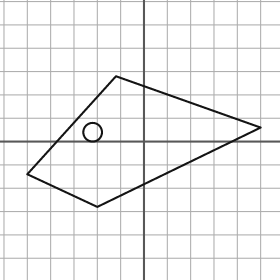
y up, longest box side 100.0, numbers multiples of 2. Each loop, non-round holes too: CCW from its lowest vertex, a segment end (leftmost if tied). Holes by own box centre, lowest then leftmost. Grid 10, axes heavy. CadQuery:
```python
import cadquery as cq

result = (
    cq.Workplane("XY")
    .moveTo(-20.0, -28.0)
    .lineTo(50.0, 6.0)
    .lineTo(-12.0, 28.0)
    .lineTo(-50.0, -14.0)
    .close()
    .moveTo(-22.0, 4.0)
    .circle(4.0)
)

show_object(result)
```